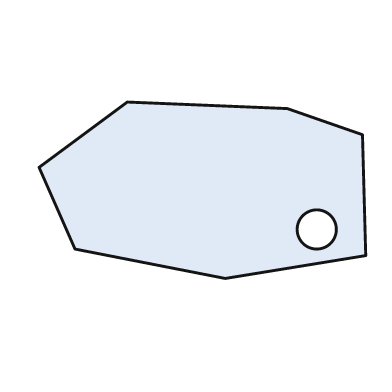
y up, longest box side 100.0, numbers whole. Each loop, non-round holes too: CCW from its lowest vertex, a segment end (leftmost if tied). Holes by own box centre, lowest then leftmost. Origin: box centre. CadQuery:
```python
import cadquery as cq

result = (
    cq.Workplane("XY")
    .moveTo(7.0, -27.0)
    .lineTo(50.0, -20.0)
    .lineTo(49.0, 17.0)
    .lineTo(26.0, 25.0)
    .lineTo(-23.0, 27.0)
    .lineTo(-50.0, 7.0)
    .lineTo(-39.0, -18.0)
    .close()
    .moveTo(35.0, -12.0)
    .circle(6.0)
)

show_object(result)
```